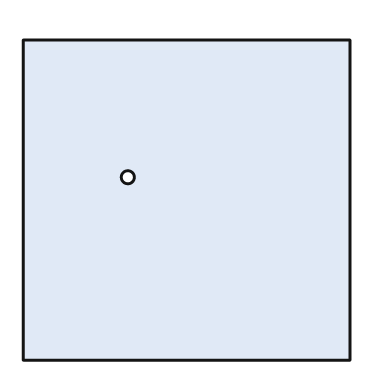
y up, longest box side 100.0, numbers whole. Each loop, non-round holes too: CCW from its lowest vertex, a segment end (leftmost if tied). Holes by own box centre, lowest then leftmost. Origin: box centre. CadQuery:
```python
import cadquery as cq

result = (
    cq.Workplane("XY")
    .moveTo(-50.0, -49.0)
    .lineTo(50.0, -49.0)
    .lineTo(50.0, 49.0)
    .lineTo(-50.0, 49.0)
    .close()
    .moveTo(-18.0, 7.0)
    .circle(2.0)
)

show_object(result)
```